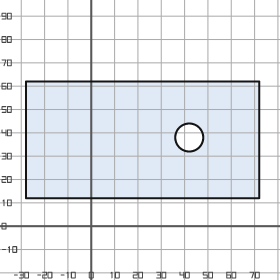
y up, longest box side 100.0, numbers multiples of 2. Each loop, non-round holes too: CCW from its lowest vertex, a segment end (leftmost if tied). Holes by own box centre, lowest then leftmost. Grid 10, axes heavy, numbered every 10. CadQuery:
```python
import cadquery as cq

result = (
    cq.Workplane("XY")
    .moveTo(-28.0, 12.0)
    .lineTo(72.0, 12.0)
    .lineTo(72.0, 62.0)
    .lineTo(-28.0, 62.0)
    .close()
    .moveTo(42.0, 38.0)
    .circle(6.0)
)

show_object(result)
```